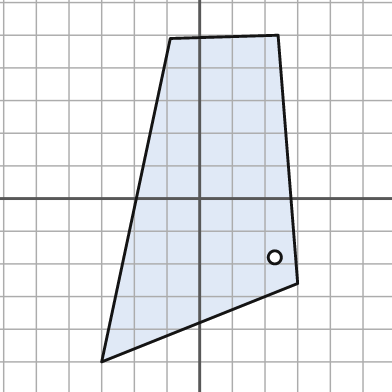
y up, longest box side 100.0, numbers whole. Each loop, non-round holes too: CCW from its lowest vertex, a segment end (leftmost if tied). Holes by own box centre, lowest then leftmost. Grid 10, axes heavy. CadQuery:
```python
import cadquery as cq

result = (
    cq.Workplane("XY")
    .moveTo(-30.0, -50.0)
    .lineTo(30.0, -26.0)
    .lineTo(24.0, 50.0)
    .lineTo(-9.0, 49.0)
    .close()
    .moveTo(23.0, -18.0)
    .circle(2.0)
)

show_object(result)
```